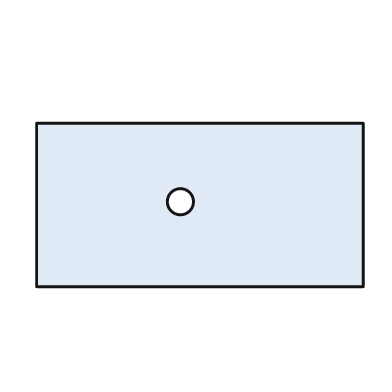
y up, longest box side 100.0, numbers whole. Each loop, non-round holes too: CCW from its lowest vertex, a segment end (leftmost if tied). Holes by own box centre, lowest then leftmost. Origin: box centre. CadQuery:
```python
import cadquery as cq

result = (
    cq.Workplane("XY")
    .moveTo(-50.0, -25.0)
    .lineTo(50.0, -25.0)
    .lineTo(50.0, 25.0)
    .lineTo(-50.0, 25.0)
    .close()
    .moveTo(-6.0, 1.0)
    .circle(4.0)
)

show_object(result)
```